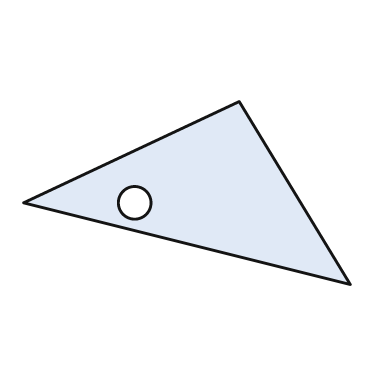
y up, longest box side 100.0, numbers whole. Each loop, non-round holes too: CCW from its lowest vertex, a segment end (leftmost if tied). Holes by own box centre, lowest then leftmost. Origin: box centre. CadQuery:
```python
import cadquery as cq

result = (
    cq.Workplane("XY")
    .moveTo(50.0, -28.0)
    .lineTo(16.0, 28.0)
    .lineTo(-50.0, -3.0)
    .close()
    .moveTo(-16.0, -3.0)
    .circle(5.0)
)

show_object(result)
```